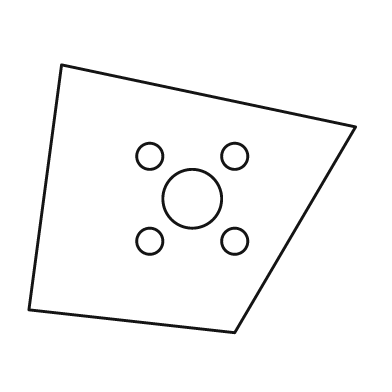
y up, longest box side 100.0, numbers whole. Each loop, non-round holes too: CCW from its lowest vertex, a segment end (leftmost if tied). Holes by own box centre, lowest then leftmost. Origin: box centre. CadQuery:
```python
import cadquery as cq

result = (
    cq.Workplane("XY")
    .moveTo(13.0, -41.0)
    .lineTo(50.0, 22.0)
    .lineTo(-40.0, 41.0)
    .lineTo(-50.0, -34.0)
    .close()
    .moveTo(-13.0, -13.0)
    .circle(4.0)
    .moveTo(13.0, -13.0)
    .circle(4.0)
    .moveTo(0.0, 0.0)
    .circle(9.0)
    .moveTo(-13.0, 13.0)
    .circle(4.0)
    .moveTo(13.0, 13.0)
    .circle(4.0)
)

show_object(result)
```